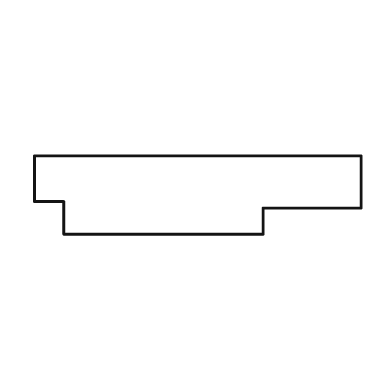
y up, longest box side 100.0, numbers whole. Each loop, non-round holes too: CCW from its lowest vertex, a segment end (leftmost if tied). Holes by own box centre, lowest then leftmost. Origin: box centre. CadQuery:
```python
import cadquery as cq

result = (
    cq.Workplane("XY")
    .moveTo(-41.0, -12.0)
    .lineTo(20.0, -12.0)
    .lineTo(20.0, -4.0)
    .lineTo(50.0, -4.0)
    .lineTo(50.0, 12.0)
    .lineTo(-50.0, 12.0)
    .lineTo(-50.0, -2.0)
    .lineTo(-41.0, -2.0)
    .close()
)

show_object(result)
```